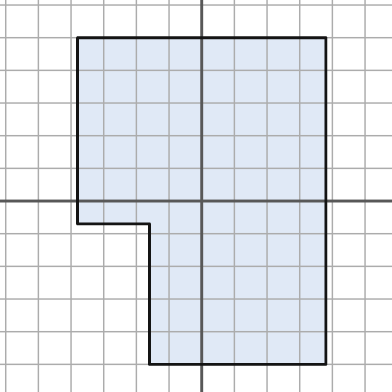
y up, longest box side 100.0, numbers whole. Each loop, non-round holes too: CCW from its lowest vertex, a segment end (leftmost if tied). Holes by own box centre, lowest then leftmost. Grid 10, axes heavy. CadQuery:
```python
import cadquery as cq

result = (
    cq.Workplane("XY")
    .moveTo(-16.0, -50.0)
    .lineTo(38.0, -50.0)
    .lineTo(38.0, 50.0)
    .lineTo(-38.0, 50.0)
    .lineTo(-38.0, -7.0)
    .lineTo(-16.0, -7.0)
    .close()
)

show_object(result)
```